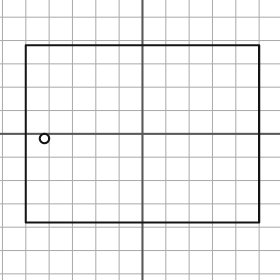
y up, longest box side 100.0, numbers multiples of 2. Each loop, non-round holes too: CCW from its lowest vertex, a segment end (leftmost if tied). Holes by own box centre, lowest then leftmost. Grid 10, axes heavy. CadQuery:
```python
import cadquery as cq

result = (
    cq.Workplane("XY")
    .moveTo(-50.0, -38.0)
    .lineTo(50.0, -38.0)
    .lineTo(50.0, 38.0)
    .lineTo(-50.0, 38.0)
    .close()
    .moveTo(-42.0, -2.0)
    .circle(2.0)
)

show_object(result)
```